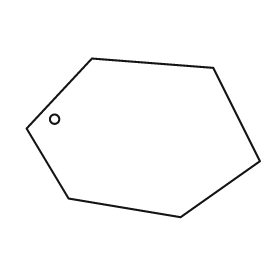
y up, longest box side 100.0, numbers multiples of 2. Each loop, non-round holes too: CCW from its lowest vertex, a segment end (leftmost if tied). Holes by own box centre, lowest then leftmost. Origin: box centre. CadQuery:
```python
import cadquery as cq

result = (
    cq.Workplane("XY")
    .moveTo(16.0, -34.0)
    .lineTo(50.0, -10.0)
    .lineTo(30.0, 30.0)
    .lineTo(-22.0, 34.0)
    .lineTo(-50.0, 4.0)
    .lineTo(-32.0, -26.0)
    .close()
    .moveTo(-38.0, 8.0)
    .circle(2.0)
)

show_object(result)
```